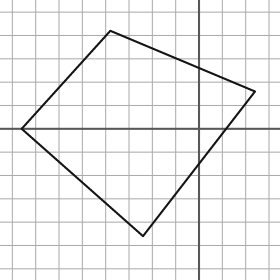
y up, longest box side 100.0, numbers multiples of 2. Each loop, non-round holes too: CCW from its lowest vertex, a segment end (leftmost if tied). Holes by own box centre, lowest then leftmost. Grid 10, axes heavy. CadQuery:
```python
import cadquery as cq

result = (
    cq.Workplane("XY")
    .moveTo(-24.0, -46.0)
    .lineTo(24.0, 16.0)
    .lineTo(-38.0, 42.0)
    .lineTo(-76.0, 0.0)
    .close()
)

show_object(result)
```